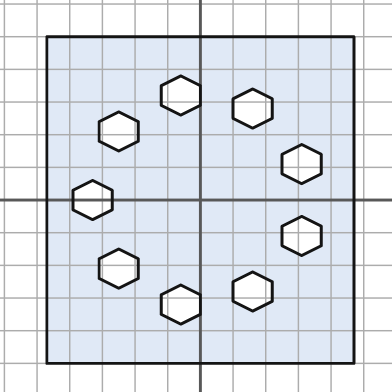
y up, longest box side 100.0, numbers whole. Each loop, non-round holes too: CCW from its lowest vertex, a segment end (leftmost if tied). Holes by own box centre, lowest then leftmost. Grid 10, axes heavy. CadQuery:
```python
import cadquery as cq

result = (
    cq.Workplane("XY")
    .moveTo(-47.0, -50.0)
    .lineTo(47.0, -50.0)
    .lineTo(47.0, 50.0)
    .lineTo(-47.0, 50.0)
    .close()
    .moveTo(-6.0, -38.0)
    .lineTo(0.0, -35.0)
    .lineTo(0.0, -29.0)
    .lineTo(-6.0, -26.0)
    .lineTo(-12.0, -29.0)
    .lineTo(-12.0, -35.0)
    .close()
    .moveTo(16.0, -34.0)
    .lineTo(22.0, -31.0)
    .lineTo(22.0, -25.0)
    .lineTo(16.0, -22.0)
    .lineTo(10.0, -25.0)
    .lineTo(10.0, -31.0)
    .close()
    .moveTo(-25.0, -27.0)
    .lineTo(-19.0, -24.0)
    .lineTo(-19.0, -18.0)
    .lineTo(-25.0, -15.0)
    .lineTo(-31.0, -18.0)
    .lineTo(-31.0, -24.0)
    .close()
    .moveTo(31.0, -17.0)
    .lineTo(37.0, -14.0)
    .lineTo(37.0, -8.0)
    .lineTo(31.0, -5.0)
    .lineTo(25.0, -8.0)
    .lineTo(25.0, -14.0)
    .close()
    .moveTo(-33.0, -6.0)
    .lineTo(-27.0, -3.0)
    .lineTo(-27.0, 3.0)
    .lineTo(-33.0, 6.0)
    .lineTo(-39.0, 3.0)
    .lineTo(-39.0, -3.0)
    .close()
    .moveTo(31.0, 5.0)
    .lineTo(37.0, 8.0)
    .lineTo(37.0, 14.0)
    .lineTo(31.0, 17.0)
    .lineTo(25.0, 14.0)
    .lineTo(25.0, 8.0)
    .close()
    .moveTo(-25.0, 15.0)
    .lineTo(-19.0, 18.0)
    .lineTo(-19.0, 24.0)
    .lineTo(-25.0, 27.0)
    .lineTo(-31.0, 24.0)
    .lineTo(-31.0, 18.0)
    .close()
    .moveTo(16.0, 22.0)
    .lineTo(22.0, 25.0)
    .lineTo(22.0, 31.0)
    .lineTo(16.0, 34.0)
    .lineTo(10.0, 31.0)
    .lineTo(10.0, 25.0)
    .close()
    .moveTo(-6.0, 26.0)
    .lineTo(0.0, 29.0)
    .lineTo(0.0, 35.0)
    .lineTo(-6.0, 38.0)
    .lineTo(-12.0, 35.0)
    .lineTo(-12.0, 29.0)
    .close()
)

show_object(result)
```